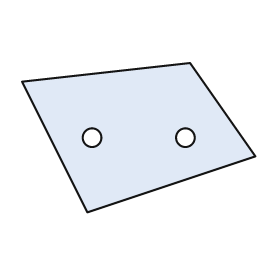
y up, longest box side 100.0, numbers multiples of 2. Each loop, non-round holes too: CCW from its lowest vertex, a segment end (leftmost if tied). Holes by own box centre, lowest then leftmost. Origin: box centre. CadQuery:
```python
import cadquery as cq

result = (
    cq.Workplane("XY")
    .moveTo(-22.0, -32.0)
    .lineTo(50.0, -8.0)
    .lineTo(22.0, 32.0)
    .lineTo(-50.0, 24.0)
    .close()
    .moveTo(-20.0, 0.0)
    .circle(4.0)
    .moveTo(20.0, 0.0)
    .circle(4.0)
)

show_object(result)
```